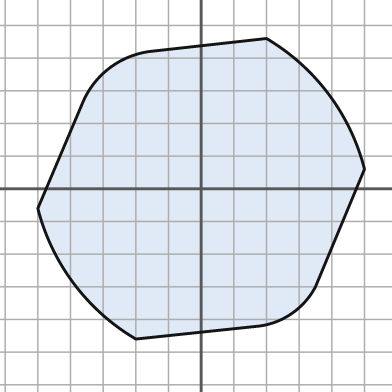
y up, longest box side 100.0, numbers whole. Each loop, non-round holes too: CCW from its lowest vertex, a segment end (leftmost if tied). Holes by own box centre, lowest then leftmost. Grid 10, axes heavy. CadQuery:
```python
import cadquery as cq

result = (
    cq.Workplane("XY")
    .moveTo(-20.0, -46.0)
    .lineTo(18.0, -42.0)
    .threePointArc((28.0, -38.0), (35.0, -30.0))
    .lineTo(50.0, 6.0)
    .threePointArc((39.0, 29.0), (20.0, 46.0))
    .lineTo(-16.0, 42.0)
    .threePointArc((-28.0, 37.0), (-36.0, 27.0))
    .lineTo(-50.0, -6.0)
    .threePointArc((-39.0, -29.0), (-20.0, -46.0))
    .close()
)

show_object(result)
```